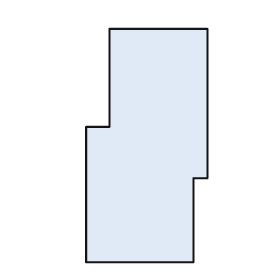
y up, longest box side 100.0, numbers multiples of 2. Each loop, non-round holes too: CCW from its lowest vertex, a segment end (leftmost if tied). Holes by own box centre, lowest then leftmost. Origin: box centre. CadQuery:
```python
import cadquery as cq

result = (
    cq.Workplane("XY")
    .moveTo(-26.0, -50.0)
    .lineTo(20.0, -50.0)
    .lineTo(20.0, -14.0)
    .lineTo(26.0, -14.0)
    .lineTo(26.0, 50.0)
    .lineTo(-16.0, 50.0)
    .lineTo(-16.0, 8.0)
    .lineTo(-26.0, 8.0)
    .close()
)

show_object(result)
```